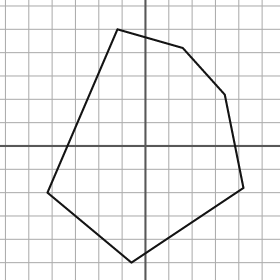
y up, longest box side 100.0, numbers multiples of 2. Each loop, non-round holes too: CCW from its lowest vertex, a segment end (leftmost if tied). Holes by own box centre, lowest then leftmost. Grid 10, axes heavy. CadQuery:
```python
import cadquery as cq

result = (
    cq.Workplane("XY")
    .moveTo(-6.0, -50.0)
    .lineTo(42.0, -18.0)
    .lineTo(34.0, 22.0)
    .lineTo(16.0, 42.0)
    .lineTo(-12.0, 50.0)
    .lineTo(-42.0, -20.0)
    .close()
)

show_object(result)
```